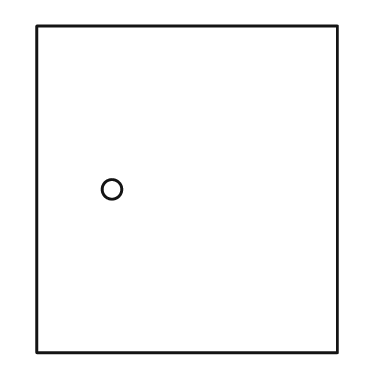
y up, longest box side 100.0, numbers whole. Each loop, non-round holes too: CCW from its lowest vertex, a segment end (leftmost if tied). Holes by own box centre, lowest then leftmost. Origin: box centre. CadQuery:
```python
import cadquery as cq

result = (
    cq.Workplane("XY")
    .moveTo(-46.0, -50.0)
    .lineTo(46.0, -50.0)
    .lineTo(46.0, 50.0)
    .lineTo(-46.0, 50.0)
    .close()
    .moveTo(-23.0, 0.0)
    .circle(3.0)
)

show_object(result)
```